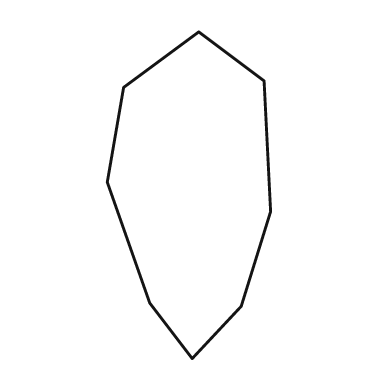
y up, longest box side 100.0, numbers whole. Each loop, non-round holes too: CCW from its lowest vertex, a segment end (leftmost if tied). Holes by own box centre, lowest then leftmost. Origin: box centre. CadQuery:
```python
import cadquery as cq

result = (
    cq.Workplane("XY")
    .moveTo(1.0, -50.0)
    .lineTo(16.0, -34.0)
    .lineTo(25.0, -5.0)
    .lineTo(23.0, 35.0)
    .lineTo(3.0, 50.0)
    .lineTo(-20.0, 33.0)
    .lineTo(-25.0, 4.0)
    .lineTo(-12.0, -33.0)
    .close()
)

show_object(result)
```